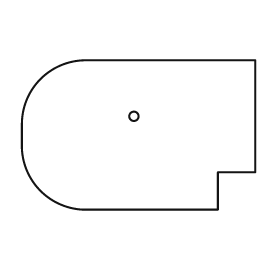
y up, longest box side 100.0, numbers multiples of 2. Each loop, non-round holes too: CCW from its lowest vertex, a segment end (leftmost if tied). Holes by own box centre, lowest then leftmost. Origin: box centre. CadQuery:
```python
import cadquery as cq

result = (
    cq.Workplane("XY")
    .moveTo(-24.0, -32.0)
    .lineTo(34.0, -32.0)
    .lineTo(34.0, -16.0)
    .lineTo(50.0, -16.0)
    .lineTo(50.0, 32.0)
    .lineTo(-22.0, 32.0)
    .threePointArc((-42.0, 24.0), (-50.0, 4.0))
    .lineTo(-50.0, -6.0)
    .threePointArc((-42.0, -24.0), (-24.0, -32.0))
    .close()
    .moveTo(-2.0, 8.0)
    .circle(2.0)
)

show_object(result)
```